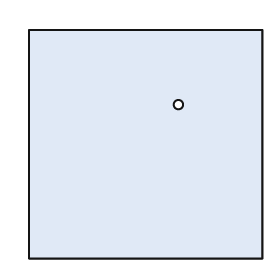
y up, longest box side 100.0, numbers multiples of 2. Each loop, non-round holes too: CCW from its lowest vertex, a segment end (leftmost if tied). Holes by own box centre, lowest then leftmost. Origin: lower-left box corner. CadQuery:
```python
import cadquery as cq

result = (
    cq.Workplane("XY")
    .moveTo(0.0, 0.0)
    .lineTo(100.0, 0.0)
    .lineTo(100.0, 98.0)
    .lineTo(0.0, 98.0)
    .close()
    .moveTo(64.0, 66.0)
    .circle(2.0)
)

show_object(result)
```